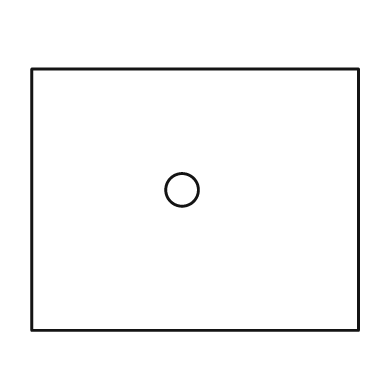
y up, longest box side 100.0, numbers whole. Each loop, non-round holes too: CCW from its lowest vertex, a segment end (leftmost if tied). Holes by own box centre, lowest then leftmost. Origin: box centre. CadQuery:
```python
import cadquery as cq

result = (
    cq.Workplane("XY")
    .moveTo(-50.0, -40.0)
    .lineTo(50.0, -40.0)
    .lineTo(50.0, 40.0)
    .lineTo(-50.0, 40.0)
    .close()
    .moveTo(-4.0, 3.0)
    .circle(5.0)
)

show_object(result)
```